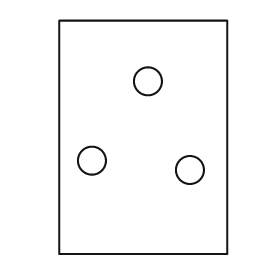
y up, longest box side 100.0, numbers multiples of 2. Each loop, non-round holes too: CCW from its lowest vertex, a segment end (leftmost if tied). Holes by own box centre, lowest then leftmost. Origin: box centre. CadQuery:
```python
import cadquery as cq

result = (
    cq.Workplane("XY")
    .moveTo(-36.0, -50.0)
    .lineTo(36.0, -50.0)
    .lineTo(36.0, 50.0)
    .lineTo(-36.0, 50.0)
    .close()
    .moveTo(20.0, -14.0)
    .circle(6.0)
    .moveTo(-22.0, -10.0)
    .circle(6.0)
    .moveTo(2.0, 24.0)
    .circle(6.0)
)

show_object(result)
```